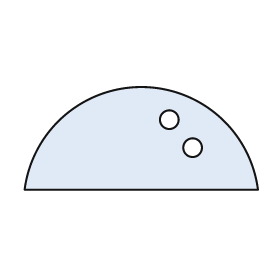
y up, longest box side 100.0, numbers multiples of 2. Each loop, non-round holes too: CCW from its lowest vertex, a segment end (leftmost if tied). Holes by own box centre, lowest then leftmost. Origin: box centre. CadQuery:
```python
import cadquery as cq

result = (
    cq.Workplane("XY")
    .moveTo(-50.0, -22.0)
    .lineTo(50.0, -22.0)
    .threePointArc((0.0, 22.0), (-50.0, -22.0))
    .close()
    .moveTo(22.0, -4.0)
    .circle(4.0)
    .moveTo(12.0, 8.0)
    .circle(4.0)
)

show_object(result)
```